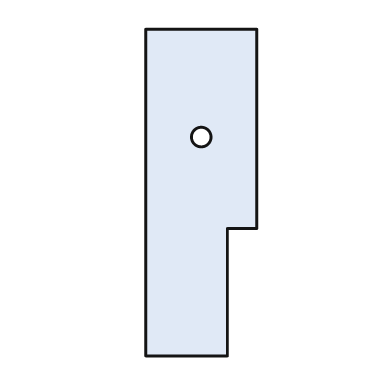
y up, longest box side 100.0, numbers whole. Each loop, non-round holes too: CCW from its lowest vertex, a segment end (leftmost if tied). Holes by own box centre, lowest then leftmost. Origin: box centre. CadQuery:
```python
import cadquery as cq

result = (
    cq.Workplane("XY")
    .moveTo(-17.0, -50.0)
    .lineTo(8.0, -50.0)
    .lineTo(8.0, -11.0)
    .lineTo(17.0, -11.0)
    .lineTo(17.0, 50.0)
    .lineTo(-17.0, 50.0)
    .close()
    .moveTo(0.0, 17.0)
    .circle(3.0)
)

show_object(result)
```